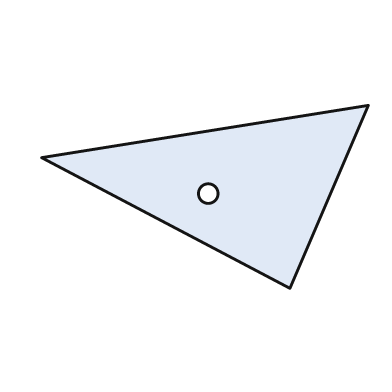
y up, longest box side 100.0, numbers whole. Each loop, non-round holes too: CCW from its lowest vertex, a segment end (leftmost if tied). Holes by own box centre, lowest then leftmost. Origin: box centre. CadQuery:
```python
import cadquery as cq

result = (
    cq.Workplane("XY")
    .moveTo(26.0, -28.0)
    .lineTo(50.0, 28.0)
    .lineTo(-50.0, 12.0)
    .close()
    .moveTo(1.0, 1.0)
    .circle(3.0)
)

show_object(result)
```